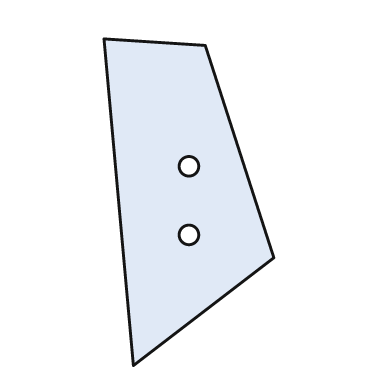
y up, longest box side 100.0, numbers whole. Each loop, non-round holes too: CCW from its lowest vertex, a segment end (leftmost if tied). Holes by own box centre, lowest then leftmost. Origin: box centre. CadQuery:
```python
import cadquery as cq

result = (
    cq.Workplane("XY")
    .moveTo(-17.0, -50.0)
    .lineTo(26.0, -17.0)
    .lineTo(5.0, 48.0)
    .lineTo(-26.0, 50.0)
    .close()
    .moveTo(0.0, -10.0)
    .circle(3.0)
    .moveTo(0.0, 11.0)
    .circle(3.0)
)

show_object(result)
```